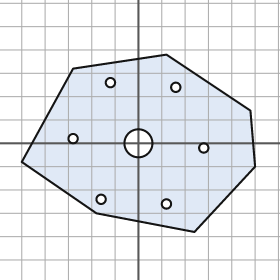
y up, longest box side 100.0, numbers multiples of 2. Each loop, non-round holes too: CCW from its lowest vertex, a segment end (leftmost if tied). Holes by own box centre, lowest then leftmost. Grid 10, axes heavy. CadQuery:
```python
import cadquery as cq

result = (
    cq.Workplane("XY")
    .moveTo(24.0, -38.0)
    .lineTo(50.0, -10.0)
    .lineTo(48.0, 14.0)
    .lineTo(12.0, 38.0)
    .lineTo(-28.0, 32.0)
    .lineTo(-50.0, -8.0)
    .lineTo(-18.0, -30.0)
    .close()
    .moveTo(12.0, -26.0)
    .circle(2.0)
    .moveTo(-16.0, -24.0)
    .circle(2.0)
    .moveTo(28.0, -2.0)
    .circle(2.0)
    .moveTo(0.0, 0.0)
    .circle(6.0)
    .moveTo(-28.0, 2.0)
    .circle(2.0)
    .moveTo(16.0, 24.0)
    .circle(2.0)
    .moveTo(-12.0, 26.0)
    .circle(2.0)
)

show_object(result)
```